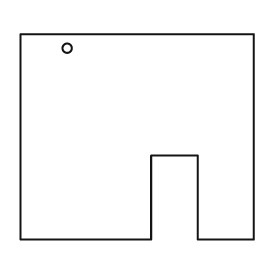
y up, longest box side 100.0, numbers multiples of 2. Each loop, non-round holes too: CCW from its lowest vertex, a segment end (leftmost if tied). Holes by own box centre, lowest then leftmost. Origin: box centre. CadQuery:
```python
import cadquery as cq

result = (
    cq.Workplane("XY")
    .moveTo(-50.0, -44.0)
    .lineTo(6.0, -44.0)
    .lineTo(6.0, -8.0)
    .lineTo(26.0, -8.0)
    .lineTo(26.0, -44.0)
    .lineTo(50.0, -44.0)
    .lineTo(50.0, 44.0)
    .lineTo(-50.0, 44.0)
    .close()
    .moveTo(-30.0, 38.0)
    .circle(2.0)
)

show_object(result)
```